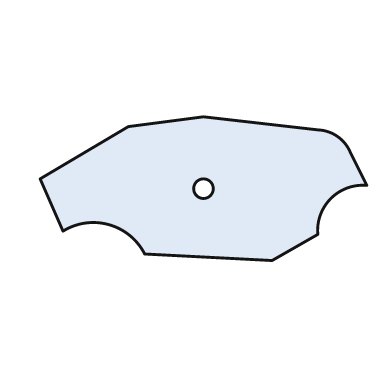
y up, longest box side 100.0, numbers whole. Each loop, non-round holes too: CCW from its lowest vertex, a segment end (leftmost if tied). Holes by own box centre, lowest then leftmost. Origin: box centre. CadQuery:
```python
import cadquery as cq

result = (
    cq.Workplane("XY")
    .moveTo(21.0, -22.0)
    .lineTo(35.0, -14.0)
    .threePointArc((39.0, -3.0), (50.0, 1.0))
    .lineTo(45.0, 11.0)
    .threePointArc((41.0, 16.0), (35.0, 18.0))
    .lineTo(0.0, 22.0)
    .lineTo(-23.0, 19.0)
    .lineTo(-50.0, 3.0)
    .lineTo(-43.0, -13.0)
    .threePointArc((-29.0, -11.0), (-18.0, -20.0))
    .close()
    .moveTo(0.0, 0.0)
    .circle(3.0)
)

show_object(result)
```